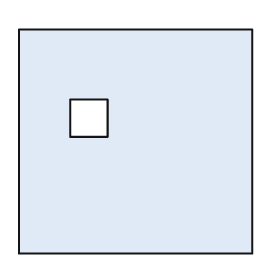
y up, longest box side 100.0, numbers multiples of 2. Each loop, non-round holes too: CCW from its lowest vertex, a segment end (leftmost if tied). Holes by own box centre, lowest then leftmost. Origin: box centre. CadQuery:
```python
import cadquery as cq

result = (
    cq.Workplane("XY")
    .moveTo(-50.0, -48.0)
    .lineTo(50.0, -48.0)
    .lineTo(50.0, 48.0)
    .lineTo(-50.0, 48.0)
    .close()
    .moveTo(-28.0, 2.0)
    .lineTo(-12.0, 2.0)
    .lineTo(-12.0, 18.0)
    .lineTo(-28.0, 18.0)
    .close()
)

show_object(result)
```